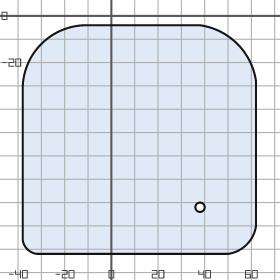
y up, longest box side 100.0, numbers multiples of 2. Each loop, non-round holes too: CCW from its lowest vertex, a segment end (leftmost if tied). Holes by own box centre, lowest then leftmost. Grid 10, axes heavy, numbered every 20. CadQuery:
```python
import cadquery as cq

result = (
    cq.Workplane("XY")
    .moveTo(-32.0, -102.0)
    .lineTo(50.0, -102.0)
    .threePointArc((58.0, -98.0), (62.0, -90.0))
    .lineTo(62.0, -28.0)
    .threePointArc((54.0, -12.0), (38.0, -4.0))
    .lineTo(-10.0, -4.0)
    .threePointArc((-30.0, -12.0), (-38.0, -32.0))
    .lineTo(-38.0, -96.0)
    .threePointArc((-36.0, -100.0), (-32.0, -102.0))
    .close()
    .moveTo(38.0, -82.0)
    .circle(2.0)
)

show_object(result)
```